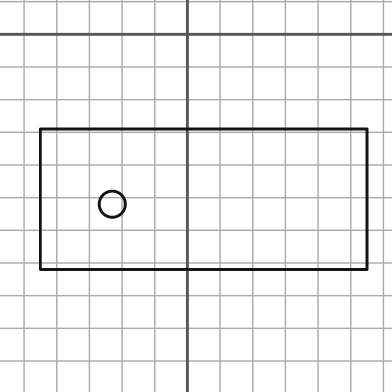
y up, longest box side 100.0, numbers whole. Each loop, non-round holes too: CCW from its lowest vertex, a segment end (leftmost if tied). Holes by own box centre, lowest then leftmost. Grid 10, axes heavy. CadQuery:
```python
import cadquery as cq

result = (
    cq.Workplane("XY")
    .moveTo(-45.0, -72.0)
    .lineTo(55.0, -72.0)
    .lineTo(55.0, -29.0)
    .lineTo(-45.0, -29.0)
    .close()
    .moveTo(-23.0, -52.0)
    .circle(4.0)
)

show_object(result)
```